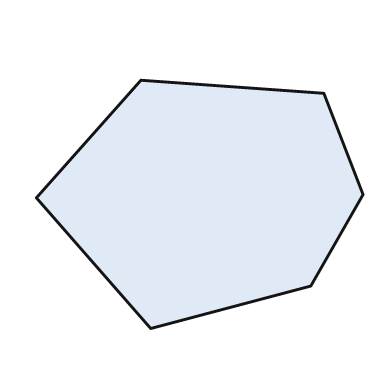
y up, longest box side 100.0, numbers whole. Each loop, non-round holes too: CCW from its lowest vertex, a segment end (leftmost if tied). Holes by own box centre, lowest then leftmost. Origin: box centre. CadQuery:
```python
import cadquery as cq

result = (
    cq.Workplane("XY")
    .moveTo(-15.0, -38.0)
    .lineTo(34.0, -25.0)
    .lineTo(50.0, 3.0)
    .lineTo(38.0, 34.0)
    .lineTo(-18.0, 38.0)
    .lineTo(-50.0, 2.0)
    .close()
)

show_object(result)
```